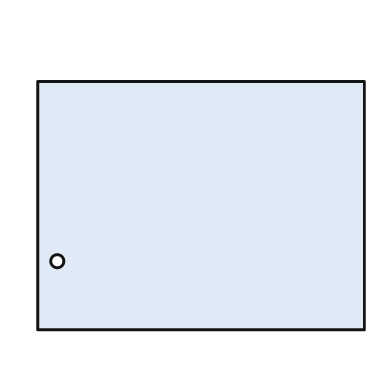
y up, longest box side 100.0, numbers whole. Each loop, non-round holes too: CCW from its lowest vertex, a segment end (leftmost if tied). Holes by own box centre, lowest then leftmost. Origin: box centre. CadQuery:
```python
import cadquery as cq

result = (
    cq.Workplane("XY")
    .moveTo(-50.0, -38.0)
    .lineTo(50.0, -38.0)
    .lineTo(50.0, 38.0)
    .lineTo(-50.0, 38.0)
    .close()
    .moveTo(-44.0, -17.0)
    .circle(2.0)
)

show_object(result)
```